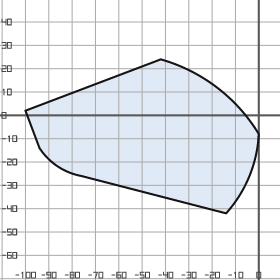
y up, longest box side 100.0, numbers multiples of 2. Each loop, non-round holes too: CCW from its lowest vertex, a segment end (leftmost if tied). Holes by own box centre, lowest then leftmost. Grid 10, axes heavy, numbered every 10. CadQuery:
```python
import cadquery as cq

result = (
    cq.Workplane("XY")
    .moveTo(-14.0, -42.0)
    .threePointArc((-4.0, -26.0), (0.0, -8.0))
    .threePointArc((-18.0, 12.0), (-42.0, 24.0))
    .lineTo(-100.0, 2.0)
    .lineTo(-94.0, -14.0)
    .threePointArc((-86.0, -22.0), (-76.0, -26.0))
    .close()
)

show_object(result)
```